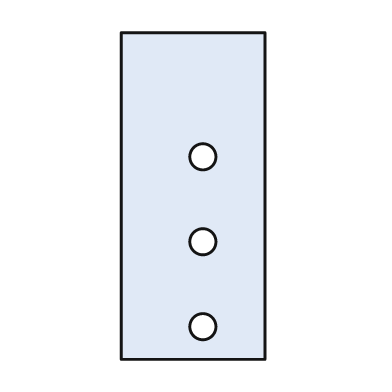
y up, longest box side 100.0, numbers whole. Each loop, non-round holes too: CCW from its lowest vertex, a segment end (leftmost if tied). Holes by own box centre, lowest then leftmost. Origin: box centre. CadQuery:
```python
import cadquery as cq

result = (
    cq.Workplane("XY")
    .moveTo(-22.0, -50.0)
    .lineTo(22.0, -50.0)
    .lineTo(22.0, 50.0)
    .lineTo(-22.0, 50.0)
    .close()
    .moveTo(3.0, -40.0)
    .circle(4.0)
    .moveTo(3.0, -14.0)
    .circle(4.0)
    .moveTo(3.0, 12.0)
    .circle(4.0)
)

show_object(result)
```